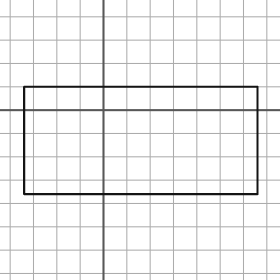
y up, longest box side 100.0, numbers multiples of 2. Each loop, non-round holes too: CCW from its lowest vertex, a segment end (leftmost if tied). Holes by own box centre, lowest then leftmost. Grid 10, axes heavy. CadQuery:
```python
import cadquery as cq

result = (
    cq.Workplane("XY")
    .moveTo(-34.0, -36.0)
    .lineTo(66.0, -36.0)
    .lineTo(66.0, 10.0)
    .lineTo(-34.0, 10.0)
    .close()
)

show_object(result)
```